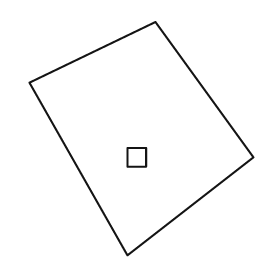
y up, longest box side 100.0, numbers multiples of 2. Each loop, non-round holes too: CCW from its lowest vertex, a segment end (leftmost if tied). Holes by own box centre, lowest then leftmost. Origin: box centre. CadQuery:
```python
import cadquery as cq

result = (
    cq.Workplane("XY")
    .moveTo(-6.0, -50.0)
    .lineTo(48.0, -8.0)
    .lineTo(6.0, 50.0)
    .lineTo(-48.0, 24.0)
    .close()
    .moveTo(-6.0, -12.0)
    .lineTo(2.0, -12.0)
    .lineTo(2.0, -4.0)
    .lineTo(-6.0, -4.0)
    .close()
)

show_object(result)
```